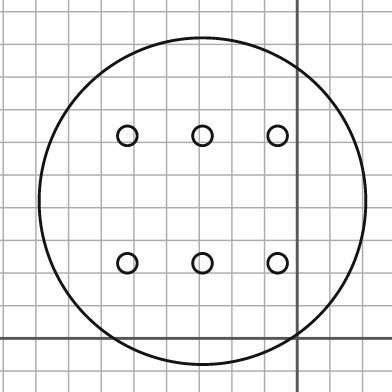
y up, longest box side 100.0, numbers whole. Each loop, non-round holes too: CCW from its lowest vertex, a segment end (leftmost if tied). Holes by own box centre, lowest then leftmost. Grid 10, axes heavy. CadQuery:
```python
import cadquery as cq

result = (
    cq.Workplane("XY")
    .moveTo(-29.0, 42.0)
    .circle(50.0)
    .moveTo(-52.0, 23.0)
    .circle(3.0)
    .moveTo(-29.0, 23.0)
    .circle(3.0)
    .moveTo(-6.0, 23.0)
    .circle(3.0)
    .moveTo(-52.0, 62.0)
    .circle(3.0)
    .moveTo(-29.0, 62.0)
    .circle(3.0)
    .moveTo(-6.0, 62.0)
    .circle(3.0)
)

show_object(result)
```